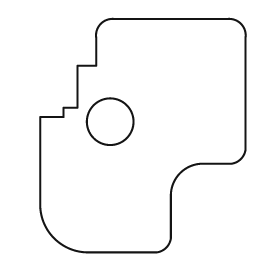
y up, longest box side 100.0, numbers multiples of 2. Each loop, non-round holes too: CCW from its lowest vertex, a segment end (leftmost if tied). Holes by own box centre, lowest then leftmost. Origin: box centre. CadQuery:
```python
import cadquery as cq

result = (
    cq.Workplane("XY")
    .moveTo(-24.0, -50.0)
    .lineTo(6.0, -50.0)
    .threePointArc((10.0, -48.0), (12.0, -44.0))
    .lineTo(12.0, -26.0)
    .threePointArc((16.0, -16.0), (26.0, -12.0))
    .lineTo(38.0, -12.0)
    .threePointArc((42.0, -10.0), (44.0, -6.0))
    .lineTo(44.0, 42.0)
    .threePointArc((42.0, 48.0), (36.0, 50.0))
    .lineTo(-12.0, 50.0)
    .threePointArc((-18.0, 48.0), (-20.0, 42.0))
    .lineTo(-20.0, 30.0)
    .lineTo(-28.0, 30.0)
    .lineTo(-28.0, 12.0)
    .lineTo(-34.0, 12.0)
    .lineTo(-34.0, 8.0)
    .lineTo(-44.0, 8.0)
    .lineTo(-44.0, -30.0)
    .threePointArc((-38.0, -44.0), (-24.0, -50.0))
    .close()
    .moveTo(-14.0, 6.0)
    .circle(10.0)
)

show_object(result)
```